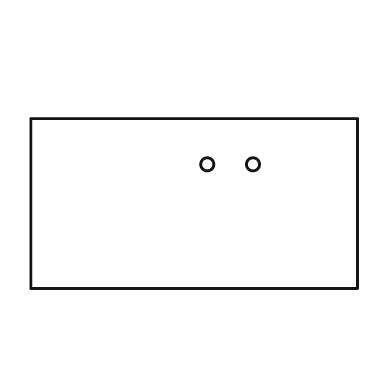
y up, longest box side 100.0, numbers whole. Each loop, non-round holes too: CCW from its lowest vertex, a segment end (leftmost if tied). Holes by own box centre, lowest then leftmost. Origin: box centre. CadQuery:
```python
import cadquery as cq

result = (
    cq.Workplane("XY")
    .moveTo(-50.0, -26.0)
    .lineTo(50.0, -26.0)
    .lineTo(50.0, 26.0)
    .lineTo(-50.0, 26.0)
    .close()
    .moveTo(4.0, 12.0)
    .circle(2.0)
    .moveTo(18.0, 12.0)
    .circle(2.0)
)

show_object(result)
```